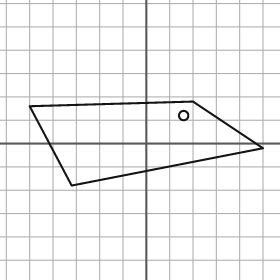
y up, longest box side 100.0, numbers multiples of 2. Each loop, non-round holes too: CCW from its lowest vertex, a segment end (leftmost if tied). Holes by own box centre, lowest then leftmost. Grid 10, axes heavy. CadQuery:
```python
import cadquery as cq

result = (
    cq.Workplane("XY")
    .moveTo(-32.0, -18.0)
    .lineTo(50.0, -2.0)
    .lineTo(20.0, 18.0)
    .lineTo(-50.0, 16.0)
    .close()
    .moveTo(16.0, 12.0)
    .circle(2.0)
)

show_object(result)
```